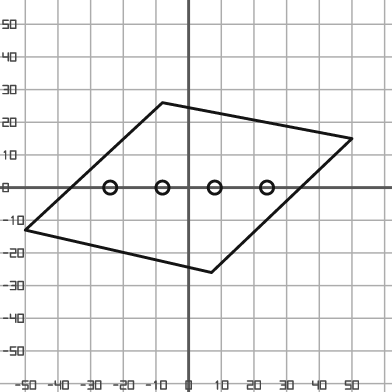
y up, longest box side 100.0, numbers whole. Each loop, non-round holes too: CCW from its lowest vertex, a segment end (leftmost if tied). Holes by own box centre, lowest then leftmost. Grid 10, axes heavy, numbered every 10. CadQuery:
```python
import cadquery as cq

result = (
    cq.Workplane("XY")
    .moveTo(7.0, -26.0)
    .lineTo(50.0, 15.0)
    .lineTo(-8.0, 26.0)
    .lineTo(-50.0, -13.0)
    .close()
    .moveTo(-24.0, 0.0)
    .circle(2.0)
    .moveTo(-8.0, 0.0)
    .circle(2.0)
    .moveTo(8.0, 0.0)
    .circle(2.0)
    .moveTo(24.0, 0.0)
    .circle(2.0)
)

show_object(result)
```